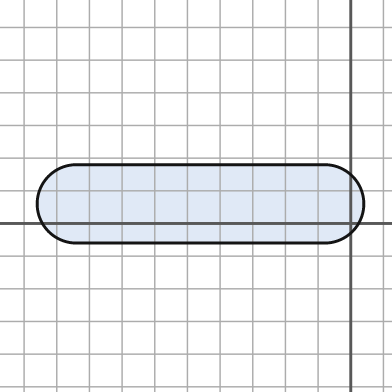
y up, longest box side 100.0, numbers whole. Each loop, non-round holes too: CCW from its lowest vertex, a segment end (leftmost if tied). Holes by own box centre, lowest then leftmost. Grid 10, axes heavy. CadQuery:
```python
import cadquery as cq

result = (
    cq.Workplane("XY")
    .moveTo(-84.0, -6.0)
    .lineTo(-8.0, -6.0)
    .threePointArc((4.0, 6.0), (-8.0, 18.0))
    .lineTo(-84.0, 18.0)
    .threePointArc((-96.0, 6.0), (-84.0, -6.0))
    .close()
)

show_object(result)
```